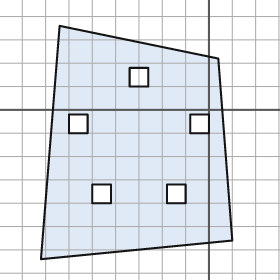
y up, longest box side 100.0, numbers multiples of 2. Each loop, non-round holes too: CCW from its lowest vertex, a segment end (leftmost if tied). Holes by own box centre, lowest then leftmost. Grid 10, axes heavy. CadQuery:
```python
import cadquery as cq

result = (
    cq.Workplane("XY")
    .moveTo(-72.0, -64.0)
    .lineTo(10.0, -56.0)
    .lineTo(4.0, 22.0)
    .lineTo(-64.0, 36.0)
    .close()
    .moveTo(-50.0, -40.0)
    .lineTo(-42.0, -40.0)
    .lineTo(-42.0, -32.0)
    .lineTo(-50.0, -32.0)
    .close()
    .moveTo(-18.0, -40.0)
    .lineTo(-10.0, -40.0)
    .lineTo(-10.0, -32.0)
    .lineTo(-18.0, -32.0)
    .close()
    .moveTo(-60.0, -10.0)
    .lineTo(-52.0, -10.0)
    .lineTo(-52.0, -2.0)
    .lineTo(-60.0, -2.0)
    .close()
    .moveTo(-8.0, -10.0)
    .lineTo(0.0, -10.0)
    .lineTo(0.0, -2.0)
    .lineTo(-8.0, -2.0)
    .close()
    .moveTo(-34.0, 10.0)
    .lineTo(-26.0, 10.0)
    .lineTo(-26.0, 18.0)
    .lineTo(-34.0, 18.0)
    .close()
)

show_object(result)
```